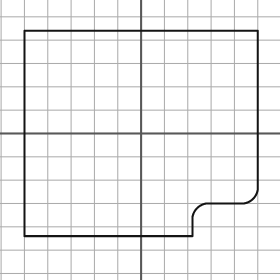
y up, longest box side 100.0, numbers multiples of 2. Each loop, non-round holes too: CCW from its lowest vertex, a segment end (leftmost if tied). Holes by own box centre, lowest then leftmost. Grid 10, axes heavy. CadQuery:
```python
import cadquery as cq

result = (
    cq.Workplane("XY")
    .moveTo(-50.0, -44.0)
    .lineTo(22.0, -44.0)
    .lineTo(22.0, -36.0)
    .threePointArc((24.0, -32.0), (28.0, -30.0))
    .lineTo(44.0, -30.0)
    .threePointArc((48.0, -28.0), (50.0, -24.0))
    .lineTo(50.0, 44.0)
    .lineTo(-50.0, 44.0)
    .close()
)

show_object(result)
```